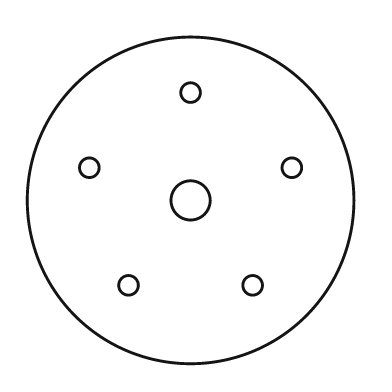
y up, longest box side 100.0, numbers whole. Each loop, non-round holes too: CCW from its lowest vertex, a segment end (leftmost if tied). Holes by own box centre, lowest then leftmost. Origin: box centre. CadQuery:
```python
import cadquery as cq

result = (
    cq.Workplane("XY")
    .moveTo(0.0, 0.0)
    .circle(50.0)
    .moveTo(-19.0, -26.0)
    .circle(3.0)
    .moveTo(19.0, -26.0)
    .circle(3.0)
    .moveTo(0.0, 0.0)
    .circle(6.0)
    .moveTo(-31.0, 10.0)
    .circle(3.0)
    .moveTo(31.0, 10.0)
    .circle(3.0)
    .moveTo(0.0, 33.0)
    .circle(3.0)
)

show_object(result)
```